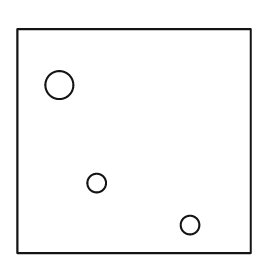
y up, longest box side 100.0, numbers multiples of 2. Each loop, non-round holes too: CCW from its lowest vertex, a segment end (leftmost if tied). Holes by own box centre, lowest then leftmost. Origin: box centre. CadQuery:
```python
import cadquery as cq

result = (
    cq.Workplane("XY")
    .moveTo(-50.0, -48.0)
    .lineTo(50.0, -48.0)
    .lineTo(50.0, 48.0)
    .lineTo(-50.0, 48.0)
    .close()
    .moveTo(24.0, -36.0)
    .circle(4.0)
    .moveTo(-16.0, -18.0)
    .circle(4.0)
    .moveTo(-32.0, 24.0)
    .circle(6.0)
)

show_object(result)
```